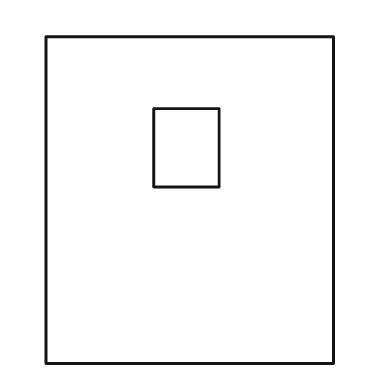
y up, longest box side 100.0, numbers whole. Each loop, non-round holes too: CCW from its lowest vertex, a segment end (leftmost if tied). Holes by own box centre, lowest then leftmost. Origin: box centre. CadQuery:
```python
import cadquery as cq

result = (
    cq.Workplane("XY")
    .moveTo(-44.0, -50.0)
    .lineTo(44.0, -50.0)
    .lineTo(44.0, 50.0)
    .lineTo(-44.0, 50.0)
    .close()
    .moveTo(-11.0, 4.0)
    .lineTo(9.0, 4.0)
    .lineTo(9.0, 28.0)
    .lineTo(-11.0, 28.0)
    .close()
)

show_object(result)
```